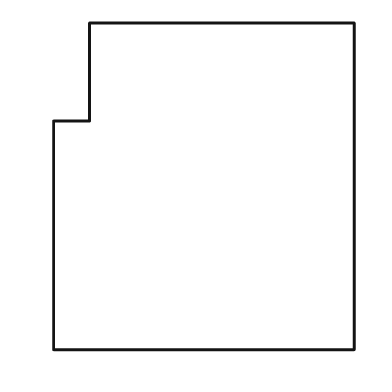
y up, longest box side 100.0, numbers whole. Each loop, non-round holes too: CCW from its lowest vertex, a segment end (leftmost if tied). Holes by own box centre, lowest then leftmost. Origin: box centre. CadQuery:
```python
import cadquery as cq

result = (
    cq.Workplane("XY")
    .moveTo(-46.0, -50.0)
    .lineTo(46.0, -50.0)
    .lineTo(46.0, 50.0)
    .lineTo(-35.0, 50.0)
    .lineTo(-35.0, 20.0)
    .lineTo(-46.0, 20.0)
    .close()
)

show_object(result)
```